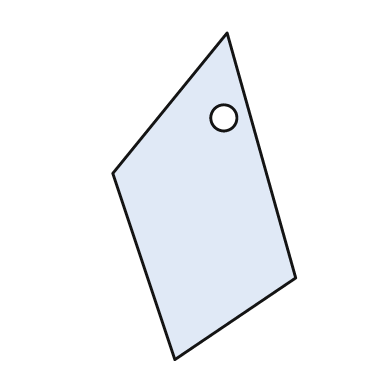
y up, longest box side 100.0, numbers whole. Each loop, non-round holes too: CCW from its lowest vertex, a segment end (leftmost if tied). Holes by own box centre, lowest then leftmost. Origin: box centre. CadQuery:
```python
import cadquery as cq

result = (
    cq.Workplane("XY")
    .moveTo(-9.0, -50.0)
    .lineTo(28.0, -25.0)
    .lineTo(7.0, 50.0)
    .lineTo(-28.0, 7.0)
    .close()
    .moveTo(6.0, 24.0)
    .circle(4.0)
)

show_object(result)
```